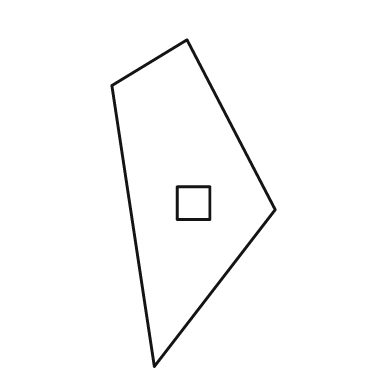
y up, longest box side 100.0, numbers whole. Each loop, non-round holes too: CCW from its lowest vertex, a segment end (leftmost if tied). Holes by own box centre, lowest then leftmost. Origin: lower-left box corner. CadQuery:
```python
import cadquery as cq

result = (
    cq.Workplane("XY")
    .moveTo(13.0, 0.0)
    .lineTo(50.0, 48.0)
    .lineTo(23.0, 100.0)
    .lineTo(0.0, 86.0)
    .close()
    .moveTo(20.0, 45.0)
    .lineTo(30.0, 45.0)
    .lineTo(30.0, 55.0)
    .lineTo(20.0, 55.0)
    .close()
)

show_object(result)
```